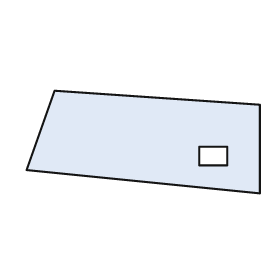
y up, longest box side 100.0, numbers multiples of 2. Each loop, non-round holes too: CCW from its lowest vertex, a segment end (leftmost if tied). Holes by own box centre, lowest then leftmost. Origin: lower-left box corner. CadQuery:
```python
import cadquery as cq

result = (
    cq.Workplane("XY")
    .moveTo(100.0, 0.0)
    .lineTo(100.0, 38.0)
    .lineTo(12.0, 44.0)
    .lineTo(0.0, 10.0)
    .close()
    .moveTo(74.0, 12.0)
    .lineTo(86.0, 12.0)
    .lineTo(86.0, 20.0)
    .lineTo(74.0, 20.0)
    .close()
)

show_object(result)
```